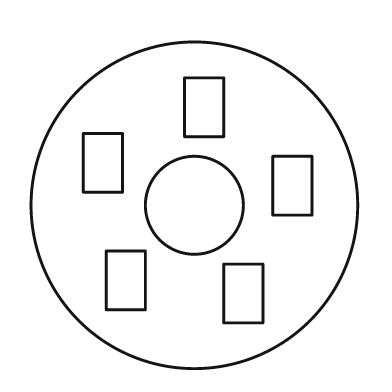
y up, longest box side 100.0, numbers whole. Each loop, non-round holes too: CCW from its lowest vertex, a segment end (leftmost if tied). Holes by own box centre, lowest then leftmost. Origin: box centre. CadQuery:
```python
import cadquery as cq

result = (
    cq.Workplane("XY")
    .moveTo(0.0, 0.0)
    .circle(50.0)
    .moveTo(9.0, -36.0)
    .lineTo(21.0, -36.0)
    .lineTo(21.0, -18.0)
    .lineTo(9.0, -18.0)
    .close()
    .moveTo(-27.0, -32.0)
    .lineTo(-15.0, -32.0)
    .lineTo(-15.0, -14.0)
    .lineTo(-27.0, -14.0)
    .close()
    .moveTo(0.0, 0.0)
    .circle(15.0)
    .moveTo(24.0, -3.0)
    .lineTo(36.0, -3.0)
    .lineTo(36.0, 15.0)
    .lineTo(24.0, 15.0)
    .close()
    .moveTo(-34.0, 4.0)
    .lineTo(-22.0, 4.0)
    .lineTo(-22.0, 22.0)
    .lineTo(-34.0, 22.0)
    .close()
    .moveTo(-3.0, 21.0)
    .lineTo(9.0, 21.0)
    .lineTo(9.0, 39.0)
    .lineTo(-3.0, 39.0)
    .close()
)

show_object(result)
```